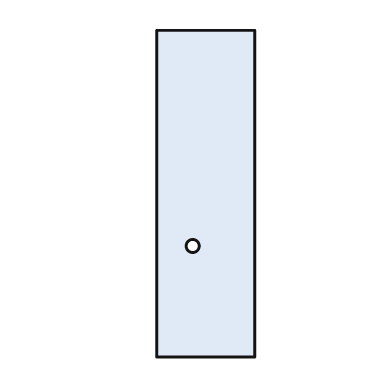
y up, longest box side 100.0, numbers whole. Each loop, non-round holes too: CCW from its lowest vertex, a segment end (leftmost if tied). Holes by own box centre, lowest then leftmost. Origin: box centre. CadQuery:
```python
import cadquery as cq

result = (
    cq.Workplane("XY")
    .moveTo(-15.0, -50.0)
    .lineTo(15.0, -50.0)
    .lineTo(15.0, 50.0)
    .lineTo(-15.0, 50.0)
    .close()
    .moveTo(-4.0, -16.0)
    .circle(2.0)
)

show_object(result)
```